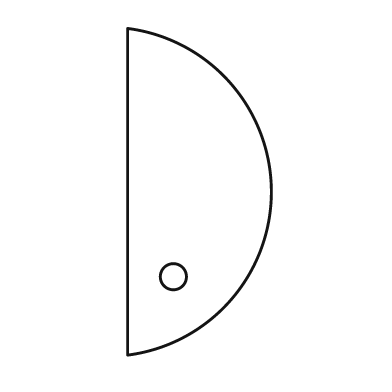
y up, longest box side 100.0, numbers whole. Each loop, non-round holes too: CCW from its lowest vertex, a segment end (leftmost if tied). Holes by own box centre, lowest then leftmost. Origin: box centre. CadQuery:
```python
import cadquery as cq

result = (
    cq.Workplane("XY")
    .moveTo(-22.0, -50.0)
    .threePointArc((22.0, 0.0), (-22.0, 50.0))
    .close()
    .moveTo(-8.0, -26.0)
    .circle(4.0)
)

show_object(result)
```